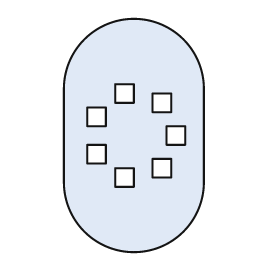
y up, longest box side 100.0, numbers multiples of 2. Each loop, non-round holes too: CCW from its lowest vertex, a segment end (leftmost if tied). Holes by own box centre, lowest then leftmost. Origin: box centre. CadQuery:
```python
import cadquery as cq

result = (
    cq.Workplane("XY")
    .moveTo(-30.0, -20.0)
    .threePointArc((0.0, -50.0), (30.0, -20.0))
    .lineTo(30.0, 20.0)
    .threePointArc((0.0, 50.0), (-30.0, 20.0))
    .close()
    .moveTo(-8.0, -22.0)
    .lineTo(0.0, -22.0)
    .lineTo(0.0, -14.0)
    .lineTo(-8.0, -14.0)
    .close()
    .moveTo(8.0, -18.0)
    .lineTo(16.0, -18.0)
    .lineTo(16.0, -10.0)
    .lineTo(8.0, -10.0)
    .close()
    .moveTo(-20.0, -12.0)
    .lineTo(-12.0, -12.0)
    .lineTo(-12.0, -4.0)
    .lineTo(-20.0, -4.0)
    .close()
    .moveTo(14.0, -4.0)
    .lineTo(22.0, -4.0)
    .lineTo(22.0, 4.0)
    .lineTo(14.0, 4.0)
    .close()
    .moveTo(-20.0, 4.0)
    .lineTo(-12.0, 4.0)
    .lineTo(-12.0, 12.0)
    .lineTo(-20.0, 12.0)
    .close()
    .moveTo(8.0, 10.0)
    .lineTo(16.0, 10.0)
    .lineTo(16.0, 18.0)
    .lineTo(8.0, 18.0)
    .close()
    .moveTo(-8.0, 14.0)
    .lineTo(0.0, 14.0)
    .lineTo(0.0, 22.0)
    .lineTo(-8.0, 22.0)
    .close()
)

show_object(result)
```